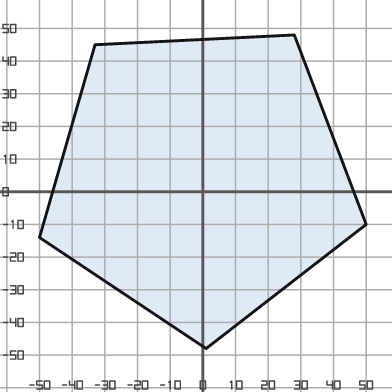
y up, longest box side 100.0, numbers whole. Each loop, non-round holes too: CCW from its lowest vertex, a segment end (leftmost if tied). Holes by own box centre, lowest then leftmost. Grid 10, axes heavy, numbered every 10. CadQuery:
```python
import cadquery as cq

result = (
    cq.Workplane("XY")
    .moveTo(1.0, -48.0)
    .lineTo(50.0, -10.0)
    .lineTo(28.0, 48.0)
    .lineTo(-33.0, 45.0)
    .lineTo(-50.0, -14.0)
    .close()
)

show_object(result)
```